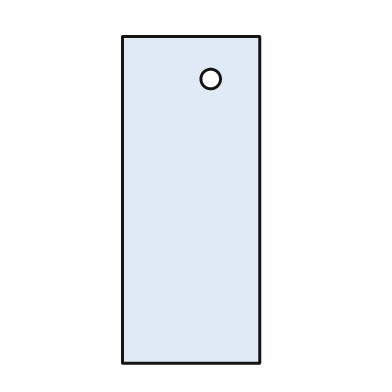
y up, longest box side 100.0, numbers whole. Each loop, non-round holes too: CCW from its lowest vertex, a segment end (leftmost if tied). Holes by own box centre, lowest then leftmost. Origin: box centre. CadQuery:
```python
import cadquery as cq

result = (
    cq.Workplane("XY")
    .moveTo(-21.0, -50.0)
    .lineTo(21.0, -50.0)
    .lineTo(21.0, 50.0)
    .lineTo(-21.0, 50.0)
    .close()
    .moveTo(6.0, 37.0)
    .circle(3.0)
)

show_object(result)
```